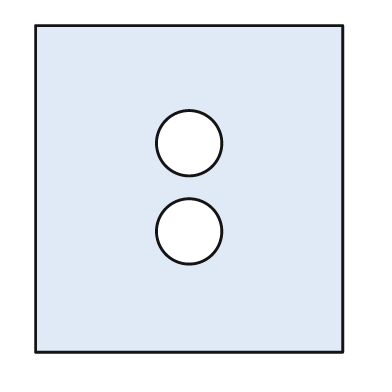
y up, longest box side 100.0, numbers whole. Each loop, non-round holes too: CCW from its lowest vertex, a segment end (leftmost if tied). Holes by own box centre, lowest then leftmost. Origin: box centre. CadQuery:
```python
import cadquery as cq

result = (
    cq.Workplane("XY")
    .moveTo(-47.0, -50.0)
    .lineTo(47.0, -50.0)
    .lineTo(47.0, 50.0)
    .lineTo(-47.0, 50.0)
    .close()
    .moveTo(0.0, -13.0)
    .circle(10.0)
    .moveTo(0.0, 14.0)
    .circle(10.0)
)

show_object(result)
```